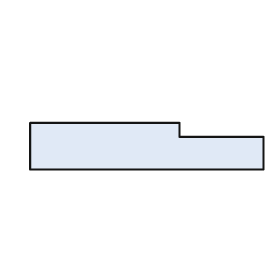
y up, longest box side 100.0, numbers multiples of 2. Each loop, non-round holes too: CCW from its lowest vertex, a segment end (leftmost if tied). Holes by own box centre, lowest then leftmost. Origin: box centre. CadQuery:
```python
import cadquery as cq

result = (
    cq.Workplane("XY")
    .moveTo(-50.0, -10.0)
    .lineTo(50.0, -10.0)
    .lineTo(50.0, 4.0)
    .lineTo(14.0, 4.0)
    .lineTo(14.0, 10.0)
    .lineTo(-50.0, 10.0)
    .close()
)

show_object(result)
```